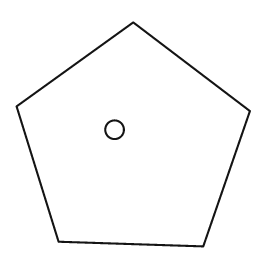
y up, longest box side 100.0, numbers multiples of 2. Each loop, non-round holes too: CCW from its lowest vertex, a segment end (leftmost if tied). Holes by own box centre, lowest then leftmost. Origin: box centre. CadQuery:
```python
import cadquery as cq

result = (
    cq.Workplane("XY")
    .moveTo(30.0, -48.0)
    .lineTo(50.0, 10.0)
    .lineTo(0.0, 48.0)
    .lineTo(-50.0, 12.0)
    .lineTo(-32.0, -46.0)
    .close()
    .moveTo(-8.0, 2.0)
    .circle(4.0)
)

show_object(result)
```